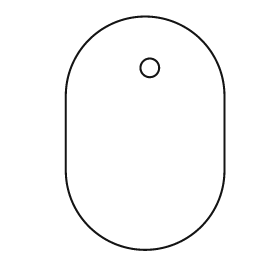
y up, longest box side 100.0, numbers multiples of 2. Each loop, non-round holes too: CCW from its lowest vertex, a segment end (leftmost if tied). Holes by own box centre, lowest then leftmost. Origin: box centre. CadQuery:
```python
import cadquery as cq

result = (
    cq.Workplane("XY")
    .moveTo(-34.0, -16.0)
    .threePointArc((0.0, -50.0), (34.0, -16.0))
    .lineTo(34.0, 16.0)
    .threePointArc((0.0, 50.0), (-34.0, 16.0))
    .close()
    .moveTo(2.0, 28.0)
    .circle(4.0)
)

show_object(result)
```